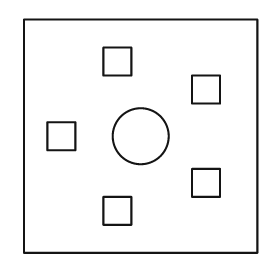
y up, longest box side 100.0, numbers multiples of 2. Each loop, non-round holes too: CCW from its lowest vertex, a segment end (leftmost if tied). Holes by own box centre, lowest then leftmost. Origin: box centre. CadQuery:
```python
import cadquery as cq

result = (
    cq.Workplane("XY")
    .moveTo(-50.0, -50.0)
    .lineTo(50.0, -50.0)
    .lineTo(50.0, 50.0)
    .lineTo(-50.0, 50.0)
    .close()
    .moveTo(-16.0, -38.0)
    .lineTo(-4.0, -38.0)
    .lineTo(-4.0, -26.0)
    .lineTo(-16.0, -26.0)
    .close()
    .moveTo(22.0, -26.0)
    .lineTo(34.0, -26.0)
    .lineTo(34.0, -14.0)
    .lineTo(22.0, -14.0)
    .close()
    .moveTo(-40.0, -6.0)
    .lineTo(-28.0, -6.0)
    .lineTo(-28.0, 6.0)
    .lineTo(-40.0, 6.0)
    .close()
    .moveTo(0.0, 0.0)
    .circle(12.0)
    .moveTo(22.0, 14.0)
    .lineTo(34.0, 14.0)
    .lineTo(34.0, 26.0)
    .lineTo(22.0, 26.0)
    .close()
    .moveTo(-16.0, 26.0)
    .lineTo(-4.0, 26.0)
    .lineTo(-4.0, 38.0)
    .lineTo(-16.0, 38.0)
    .close()
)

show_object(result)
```